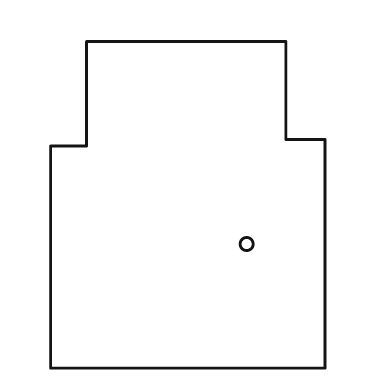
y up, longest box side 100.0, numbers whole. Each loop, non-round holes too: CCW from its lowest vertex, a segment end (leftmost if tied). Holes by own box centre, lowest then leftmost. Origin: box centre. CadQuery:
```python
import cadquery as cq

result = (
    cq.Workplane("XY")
    .moveTo(-42.0, -50.0)
    .lineTo(42.0, -50.0)
    .lineTo(42.0, 20.0)
    .lineTo(30.0, 20.0)
    .lineTo(30.0, 50.0)
    .lineTo(-31.0, 50.0)
    .lineTo(-31.0, 18.0)
    .lineTo(-42.0, 18.0)
    .close()
    .moveTo(18.0, -12.0)
    .circle(2.0)
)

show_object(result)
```